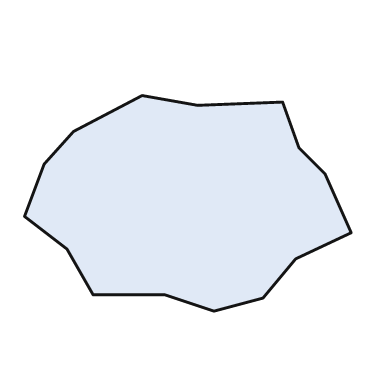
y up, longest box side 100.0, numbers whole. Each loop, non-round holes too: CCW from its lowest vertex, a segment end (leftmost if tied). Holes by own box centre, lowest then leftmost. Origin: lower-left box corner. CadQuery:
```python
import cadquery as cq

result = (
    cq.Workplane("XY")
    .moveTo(58.0, 0.0)
    .lineTo(73.0, 4.0)
    .lineTo(83.0, 16.0)
    .lineTo(100.0, 24.0)
    .lineTo(92.0, 42.0)
    .lineTo(84.0, 50.0)
    .lineTo(79.0, 64.0)
    .lineTo(53.0, 63.0)
    .lineTo(36.0, 66.0)
    .lineTo(15.0, 55.0)
    .lineTo(6.0, 45.0)
    .lineTo(0.0, 29.0)
    .lineTo(13.0, 19.0)
    .lineTo(21.0, 5.0)
    .lineTo(43.0, 5.0)
    .close()
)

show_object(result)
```